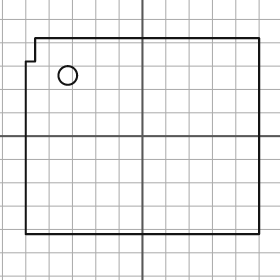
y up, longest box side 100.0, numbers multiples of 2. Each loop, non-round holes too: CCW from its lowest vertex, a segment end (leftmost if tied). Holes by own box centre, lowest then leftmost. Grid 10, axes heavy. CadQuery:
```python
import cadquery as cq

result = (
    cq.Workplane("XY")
    .moveTo(-50.0, -42.0)
    .lineTo(50.0, -42.0)
    .lineTo(50.0, 42.0)
    .lineTo(-46.0, 42.0)
    .lineTo(-46.0, 32.0)
    .lineTo(-50.0, 32.0)
    .close()
    .moveTo(-32.0, 26.0)
    .circle(4.0)
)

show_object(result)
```